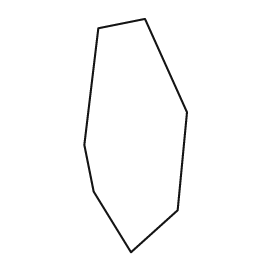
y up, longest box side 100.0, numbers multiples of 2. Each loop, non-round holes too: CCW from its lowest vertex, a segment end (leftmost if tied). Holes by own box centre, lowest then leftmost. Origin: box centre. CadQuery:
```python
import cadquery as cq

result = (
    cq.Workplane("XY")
    .moveTo(-2.0, -50.0)
    .lineTo(18.0, -32.0)
    .lineTo(22.0, 10.0)
    .lineTo(4.0, 50.0)
    .lineTo(-16.0, 46.0)
    .lineTo(-22.0, -4.0)
    .lineTo(-18.0, -24.0)
    .close()
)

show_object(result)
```